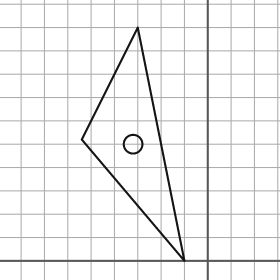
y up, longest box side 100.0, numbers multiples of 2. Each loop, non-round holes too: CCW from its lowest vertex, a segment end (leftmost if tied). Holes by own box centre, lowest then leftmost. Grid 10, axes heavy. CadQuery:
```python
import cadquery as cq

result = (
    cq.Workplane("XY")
    .moveTo(-10.0, 0.0)
    .lineTo(-30.0, 100.0)
    .lineTo(-54.0, 52.0)
    .close()
    .moveTo(-32.0, 50.0)
    .circle(4.0)
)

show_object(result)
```